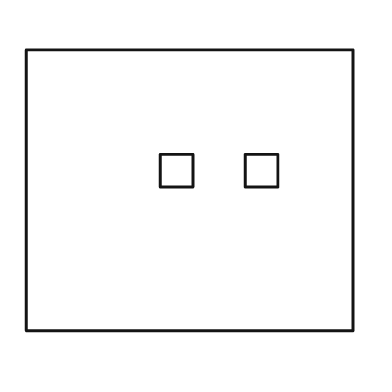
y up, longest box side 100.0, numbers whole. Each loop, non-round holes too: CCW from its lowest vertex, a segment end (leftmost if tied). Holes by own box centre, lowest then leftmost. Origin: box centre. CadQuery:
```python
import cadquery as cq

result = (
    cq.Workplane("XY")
    .moveTo(-50.0, -43.0)
    .lineTo(50.0, -43.0)
    .lineTo(50.0, 43.0)
    .lineTo(-50.0, 43.0)
    .close()
    .moveTo(-9.0, 1.0)
    .lineTo(1.0, 1.0)
    .lineTo(1.0, 11.0)
    .lineTo(-9.0, 11.0)
    .close()
    .moveTo(17.0, 1.0)
    .lineTo(27.0, 1.0)
    .lineTo(27.0, 11.0)
    .lineTo(17.0, 11.0)
    .close()
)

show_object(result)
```